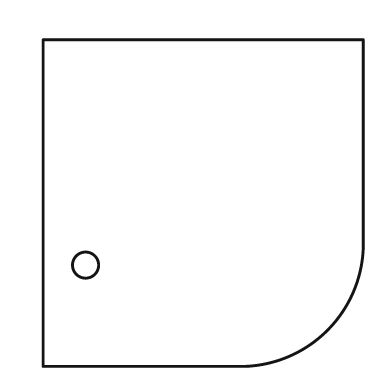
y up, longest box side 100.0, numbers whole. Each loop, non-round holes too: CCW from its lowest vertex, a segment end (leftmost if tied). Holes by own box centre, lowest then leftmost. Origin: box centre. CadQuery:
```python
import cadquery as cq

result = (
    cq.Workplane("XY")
    .moveTo(-49.0, -50.0)
    .lineTo(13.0, -50.0)
    .threePointArc((38.0, -39.0), (49.0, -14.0))
    .lineTo(49.0, 50.0)
    .lineTo(-49.0, 50.0)
    .close()
    .moveTo(-36.0, -19.0)
    .circle(4.0)
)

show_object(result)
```